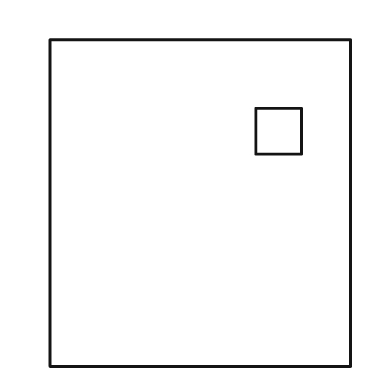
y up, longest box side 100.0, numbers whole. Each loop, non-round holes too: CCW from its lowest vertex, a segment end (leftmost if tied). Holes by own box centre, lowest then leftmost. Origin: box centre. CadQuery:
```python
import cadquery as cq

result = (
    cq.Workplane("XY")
    .moveTo(-46.0, -50.0)
    .lineTo(46.0, -50.0)
    .lineTo(46.0, 50.0)
    .lineTo(-46.0, 50.0)
    .close()
    .moveTo(17.0, 15.0)
    .lineTo(31.0, 15.0)
    .lineTo(31.0, 29.0)
    .lineTo(17.0, 29.0)
    .close()
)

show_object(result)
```